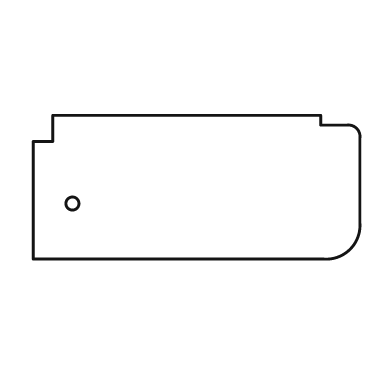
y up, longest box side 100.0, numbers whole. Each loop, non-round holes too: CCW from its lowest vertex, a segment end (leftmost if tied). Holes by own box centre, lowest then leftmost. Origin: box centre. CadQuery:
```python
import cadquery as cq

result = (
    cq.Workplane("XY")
    .moveTo(-50.0, -22.0)
    .lineTo(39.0, -22.0)
    .threePointArc((47.0, -19.0), (50.0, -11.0))
    .lineTo(50.0, 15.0)
    .threePointArc((49.0, 18.0), (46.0, 19.0))
    .lineTo(38.0, 19.0)
    .lineTo(38.0, 22.0)
    .lineTo(-44.0, 22.0)
    .lineTo(-44.0, 14.0)
    .lineTo(-50.0, 14.0)
    .close()
    .moveTo(-38.0, -5.0)
    .circle(2.0)
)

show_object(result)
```